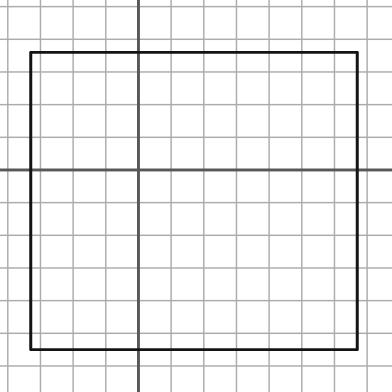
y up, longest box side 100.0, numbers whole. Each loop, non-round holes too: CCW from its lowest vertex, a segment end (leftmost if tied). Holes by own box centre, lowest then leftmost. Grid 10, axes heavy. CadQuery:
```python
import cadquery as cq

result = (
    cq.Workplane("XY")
    .moveTo(-33.0, -55.0)
    .lineTo(67.0, -55.0)
    .lineTo(67.0, 36.0)
    .lineTo(-33.0, 36.0)
    .close()
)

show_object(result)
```